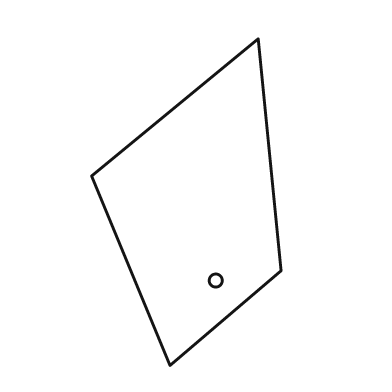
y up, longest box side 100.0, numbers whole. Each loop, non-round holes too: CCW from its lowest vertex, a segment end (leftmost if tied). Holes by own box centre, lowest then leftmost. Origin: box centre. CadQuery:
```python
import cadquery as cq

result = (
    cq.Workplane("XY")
    .moveTo(-5.0, -50.0)
    .lineTo(29.0, -21.0)
    .lineTo(22.0, 50.0)
    .lineTo(-29.0, 8.0)
    .close()
    .moveTo(9.0, -24.0)
    .circle(2.0)
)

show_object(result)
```